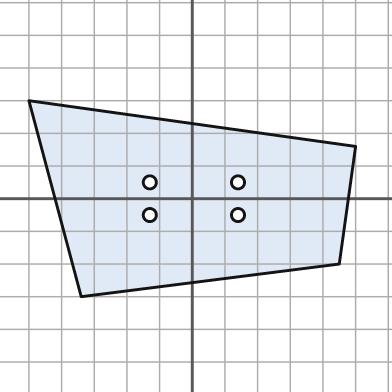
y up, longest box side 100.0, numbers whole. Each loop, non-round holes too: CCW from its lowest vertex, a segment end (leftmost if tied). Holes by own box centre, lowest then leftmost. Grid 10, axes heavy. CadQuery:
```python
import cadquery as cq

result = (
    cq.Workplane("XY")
    .moveTo(-34.0, -30.0)
    .lineTo(45.0, -20.0)
    .lineTo(50.0, 16.0)
    .lineTo(-50.0, 30.0)
    .close()
    .moveTo(-13.0, -5.0)
    .circle(2.0)
    .moveTo(14.0, -5.0)
    .circle(2.0)
    .moveTo(-13.0, 5.0)
    .circle(2.0)
    .moveTo(14.0, 5.0)
    .circle(2.0)
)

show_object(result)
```